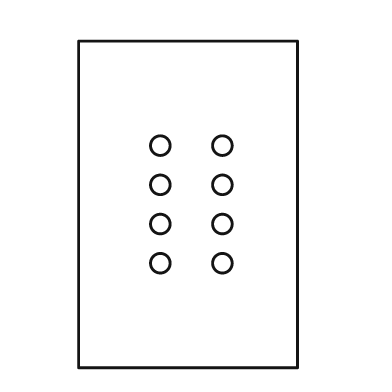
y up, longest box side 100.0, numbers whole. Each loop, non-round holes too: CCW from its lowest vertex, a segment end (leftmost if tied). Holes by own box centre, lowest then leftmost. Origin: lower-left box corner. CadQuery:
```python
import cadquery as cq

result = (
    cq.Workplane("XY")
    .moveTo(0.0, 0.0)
    .lineTo(67.0, 0.0)
    .lineTo(67.0, 100.0)
    .lineTo(0.0, 100.0)
    .close()
    .moveTo(25.0, 32.0)
    .circle(3.0)
    .moveTo(44.0, 32.0)
    .circle(3.0)
    .moveTo(25.0, 44.0)
    .circle(3.0)
    .moveTo(44.0, 44.0)
    .circle(3.0)
    .moveTo(25.0, 56.0)
    .circle(3.0)
    .moveTo(44.0, 56.0)
    .circle(3.0)
    .moveTo(25.0, 68.0)
    .circle(3.0)
    .moveTo(44.0, 68.0)
    .circle(3.0)
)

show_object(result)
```